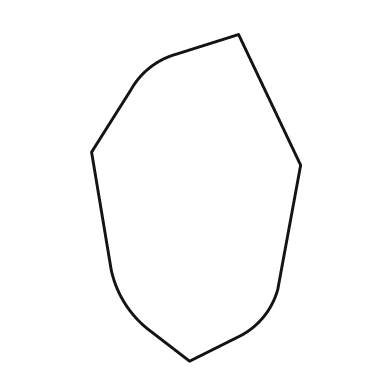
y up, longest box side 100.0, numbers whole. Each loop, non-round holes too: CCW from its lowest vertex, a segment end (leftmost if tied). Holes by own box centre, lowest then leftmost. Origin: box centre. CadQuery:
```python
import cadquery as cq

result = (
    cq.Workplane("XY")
    .moveTo(-2.0, -50.0)
    .lineTo(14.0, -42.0)
    .threePointArc((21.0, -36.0), (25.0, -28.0))
    .lineTo(32.0, 10.0)
    .lineTo(13.0, 50.0)
    .lineTo(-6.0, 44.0)
    .threePointArc((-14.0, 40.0), (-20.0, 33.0))
    .lineTo(-32.0, 14.0)
    .lineTo(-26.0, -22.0)
    .threePointArc((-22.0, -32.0), (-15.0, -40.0))
    .close()
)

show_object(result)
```